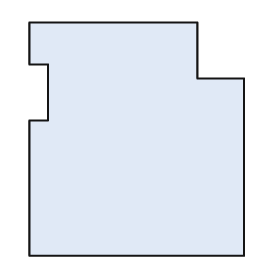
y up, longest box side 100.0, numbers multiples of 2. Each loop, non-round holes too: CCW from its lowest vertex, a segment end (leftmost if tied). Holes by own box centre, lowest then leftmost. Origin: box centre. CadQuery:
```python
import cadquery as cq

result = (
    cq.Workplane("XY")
    .moveTo(-46.0, -50.0)
    .lineTo(46.0, -50.0)
    .lineTo(46.0, 26.0)
    .lineTo(26.0, 26.0)
    .lineTo(26.0, 50.0)
    .lineTo(-46.0, 50.0)
    .lineTo(-46.0, 32.0)
    .lineTo(-38.0, 32.0)
    .lineTo(-38.0, 8.0)
    .lineTo(-46.0, 8.0)
    .close()
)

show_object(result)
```